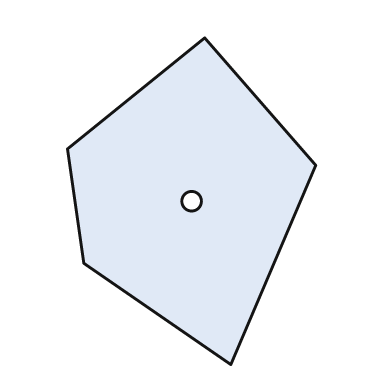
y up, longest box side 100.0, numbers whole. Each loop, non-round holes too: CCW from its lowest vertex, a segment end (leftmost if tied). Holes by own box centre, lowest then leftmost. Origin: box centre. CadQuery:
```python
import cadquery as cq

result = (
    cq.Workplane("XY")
    .moveTo(12.0, -50.0)
    .lineTo(38.0, 11.0)
    .lineTo(4.0, 50.0)
    .lineTo(-38.0, 16.0)
    .lineTo(-33.0, -19.0)
    .close()
    .moveTo(0.0, 0.0)
    .circle(3.0)
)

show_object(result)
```